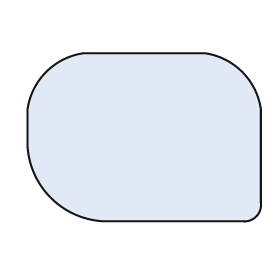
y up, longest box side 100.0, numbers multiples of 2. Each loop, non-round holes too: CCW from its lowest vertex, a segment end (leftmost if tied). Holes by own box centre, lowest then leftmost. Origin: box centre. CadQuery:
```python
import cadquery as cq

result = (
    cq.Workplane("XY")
    .moveTo(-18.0, -36.0)
    .lineTo(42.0, -36.0)
    .threePointArc((48.0, -34.0), (50.0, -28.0))
    .lineTo(50.0, 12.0)
    .threePointArc((42.0, 28.0), (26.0, 36.0))
    .lineTo(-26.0, 36.0)
    .threePointArc((-42.0, 28.0), (-50.0, 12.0))
    .lineTo(-50.0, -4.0)
    .threePointArc((-40.0, -26.0), (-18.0, -36.0))
    .close()
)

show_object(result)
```